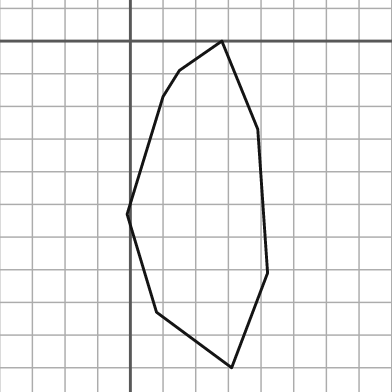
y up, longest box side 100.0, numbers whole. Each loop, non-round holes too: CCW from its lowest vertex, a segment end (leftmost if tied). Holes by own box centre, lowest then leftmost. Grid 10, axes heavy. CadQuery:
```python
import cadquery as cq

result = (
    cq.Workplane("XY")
    .moveTo(31.0, -100.0)
    .lineTo(42.0, -71.0)
    .lineTo(39.0, -27.0)
    .lineTo(28.0, 0.0)
    .lineTo(15.0, -9.0)
    .lineTo(10.0, -17.0)
    .lineTo(-1.0, -53.0)
    .lineTo(8.0, -83.0)
    .close()
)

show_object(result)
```